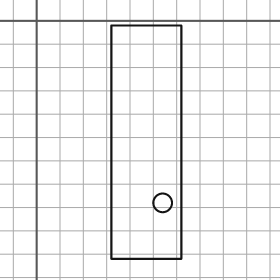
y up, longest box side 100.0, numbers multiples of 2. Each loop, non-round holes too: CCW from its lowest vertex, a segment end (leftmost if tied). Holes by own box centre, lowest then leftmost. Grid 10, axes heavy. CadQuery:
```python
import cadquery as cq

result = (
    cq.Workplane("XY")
    .moveTo(32.0, -102.0)
    .lineTo(62.0, -102.0)
    .lineTo(62.0, -2.0)
    .lineTo(32.0, -2.0)
    .close()
    .moveTo(54.0, -78.0)
    .circle(4.0)
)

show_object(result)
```